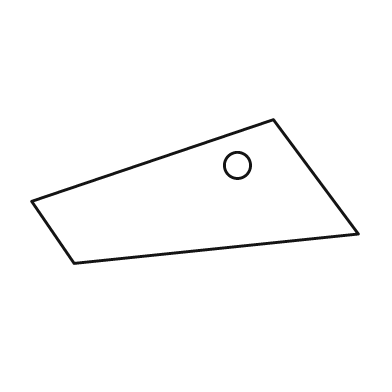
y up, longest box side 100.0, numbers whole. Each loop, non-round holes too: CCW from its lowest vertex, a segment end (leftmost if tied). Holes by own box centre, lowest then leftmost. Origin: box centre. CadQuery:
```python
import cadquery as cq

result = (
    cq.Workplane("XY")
    .moveTo(-37.0, -22.0)
    .lineTo(50.0, -13.0)
    .lineTo(24.0, 22.0)
    .lineTo(-50.0, -3.0)
    .close()
    .moveTo(13.0, 8.0)
    .circle(4.0)
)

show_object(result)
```